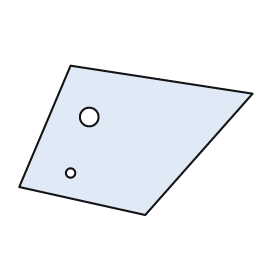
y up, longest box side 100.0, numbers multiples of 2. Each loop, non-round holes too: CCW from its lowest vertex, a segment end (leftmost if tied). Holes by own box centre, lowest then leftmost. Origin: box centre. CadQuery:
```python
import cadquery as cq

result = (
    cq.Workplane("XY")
    .moveTo(4.0, -32.0)
    .lineTo(50.0, 20.0)
    .lineTo(-28.0, 32.0)
    .lineTo(-50.0, -20.0)
    .close()
    .moveTo(-28.0, -14.0)
    .circle(2.0)
    .moveTo(-20.0, 10.0)
    .circle(4.0)
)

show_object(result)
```